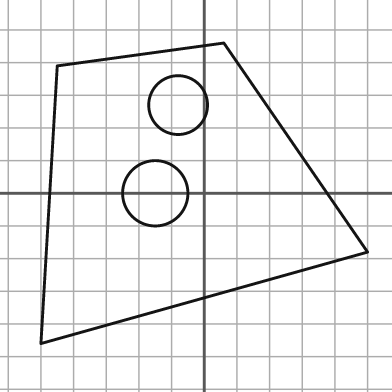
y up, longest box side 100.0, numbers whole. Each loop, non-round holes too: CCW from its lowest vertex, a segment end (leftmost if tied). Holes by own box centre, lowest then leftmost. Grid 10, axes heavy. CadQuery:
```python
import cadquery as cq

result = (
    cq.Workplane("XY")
    .moveTo(-50.0, -46.0)
    .lineTo(50.0, -18.0)
    .lineTo(6.0, 46.0)
    .lineTo(-45.0, 39.0)
    .close()
    .moveTo(-15.0, 0.0)
    .circle(10.0)
    .moveTo(-8.0, 27.0)
    .circle(9.0)
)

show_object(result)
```